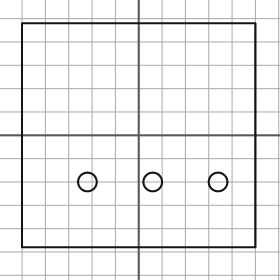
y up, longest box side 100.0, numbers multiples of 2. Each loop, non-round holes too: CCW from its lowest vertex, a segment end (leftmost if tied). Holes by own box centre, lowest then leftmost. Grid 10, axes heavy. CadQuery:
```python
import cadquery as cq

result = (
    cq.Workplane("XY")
    .moveTo(-50.0, -48.0)
    .lineTo(50.0, -48.0)
    .lineTo(50.0, 48.0)
    .lineTo(-50.0, 48.0)
    .close()
    .moveTo(-22.0, -20.0)
    .circle(4.0)
    .moveTo(6.0, -20.0)
    .circle(4.0)
    .moveTo(34.0, -20.0)
    .circle(4.0)
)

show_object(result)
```